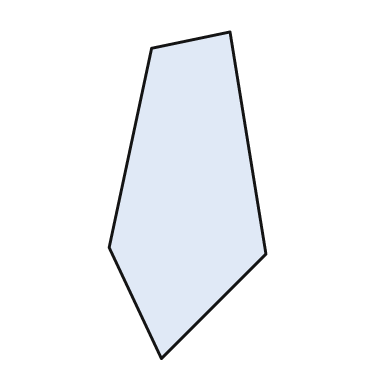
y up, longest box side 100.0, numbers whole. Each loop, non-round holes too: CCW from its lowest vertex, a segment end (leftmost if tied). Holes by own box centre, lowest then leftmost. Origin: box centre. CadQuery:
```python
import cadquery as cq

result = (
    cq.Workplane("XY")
    .moveTo(-8.0, -50.0)
    .lineTo(24.0, -18.0)
    .lineTo(13.0, 50.0)
    .lineTo(-11.0, 45.0)
    .lineTo(-24.0, -16.0)
    .close()
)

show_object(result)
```